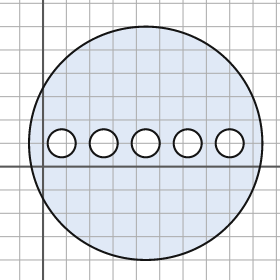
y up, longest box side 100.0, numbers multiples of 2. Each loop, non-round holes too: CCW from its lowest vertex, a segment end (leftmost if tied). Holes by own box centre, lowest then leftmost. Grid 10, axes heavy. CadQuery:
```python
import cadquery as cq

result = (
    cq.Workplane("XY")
    .moveTo(44.0, 10.0)
    .circle(50.0)
    .moveTo(8.0, 10.0)
    .circle(6.0)
    .moveTo(26.0, 10.0)
    .circle(6.0)
    .moveTo(44.0, 10.0)
    .circle(6.0)
    .moveTo(62.0, 10.0)
    .circle(6.0)
    .moveTo(80.0, 10.0)
    .circle(6.0)
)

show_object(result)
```